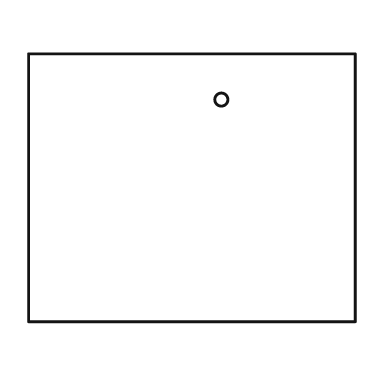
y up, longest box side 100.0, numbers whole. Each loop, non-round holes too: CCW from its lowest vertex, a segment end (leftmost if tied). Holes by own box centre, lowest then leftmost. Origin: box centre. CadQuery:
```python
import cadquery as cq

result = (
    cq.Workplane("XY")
    .moveTo(-50.0, -41.0)
    .lineTo(50.0, -41.0)
    .lineTo(50.0, 41.0)
    .lineTo(-50.0, 41.0)
    .close()
    .moveTo(9.0, 27.0)
    .circle(2.0)
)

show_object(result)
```